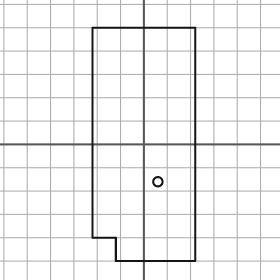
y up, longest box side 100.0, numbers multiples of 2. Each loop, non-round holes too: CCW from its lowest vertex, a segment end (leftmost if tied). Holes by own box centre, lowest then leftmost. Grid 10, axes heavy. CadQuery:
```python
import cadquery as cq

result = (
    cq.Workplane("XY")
    .moveTo(-12.0, -50.0)
    .lineTo(22.0, -50.0)
    .lineTo(22.0, 50.0)
    .lineTo(-22.0, 50.0)
    .lineTo(-22.0, -40.0)
    .lineTo(-12.0, -40.0)
    .close()
    .moveTo(6.0, -16.0)
    .circle(2.0)
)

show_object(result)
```